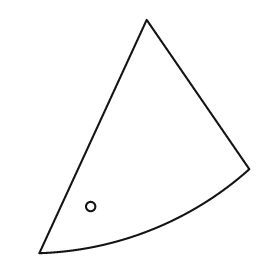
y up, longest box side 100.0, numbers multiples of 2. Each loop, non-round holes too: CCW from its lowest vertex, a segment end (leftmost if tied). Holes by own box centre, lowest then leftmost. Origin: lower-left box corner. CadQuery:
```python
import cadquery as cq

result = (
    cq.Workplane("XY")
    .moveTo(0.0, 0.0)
    .threePointArc((48.0, 10.0), (90.0, 36.0))
    .lineTo(46.0, 100.0)
    .close()
    .moveTo(22.0, 20.0)
    .circle(2.0)
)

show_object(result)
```